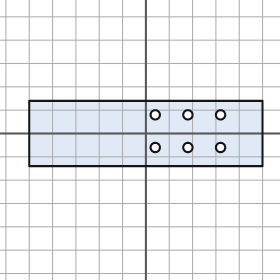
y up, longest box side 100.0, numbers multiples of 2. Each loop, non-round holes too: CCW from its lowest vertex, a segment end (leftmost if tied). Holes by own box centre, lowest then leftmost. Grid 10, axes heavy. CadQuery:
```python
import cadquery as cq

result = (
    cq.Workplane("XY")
    .moveTo(-50.0, -14.0)
    .lineTo(50.0, -14.0)
    .lineTo(50.0, 14.0)
    .lineTo(-50.0, 14.0)
    .close()
    .moveTo(4.0, -6.0)
    .circle(2.0)
    .moveTo(18.0, -6.0)
    .circle(2.0)
    .moveTo(32.0, -6.0)
    .circle(2.0)
    .moveTo(4.0, 8.0)
    .circle(2.0)
    .moveTo(18.0, 8.0)
    .circle(2.0)
    .moveTo(32.0, 8.0)
    .circle(2.0)
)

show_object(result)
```